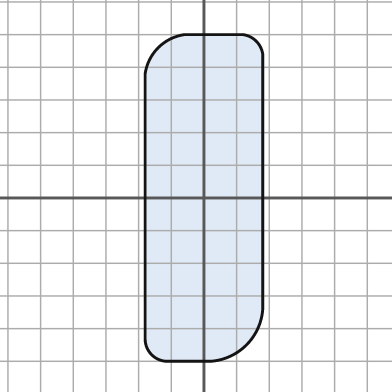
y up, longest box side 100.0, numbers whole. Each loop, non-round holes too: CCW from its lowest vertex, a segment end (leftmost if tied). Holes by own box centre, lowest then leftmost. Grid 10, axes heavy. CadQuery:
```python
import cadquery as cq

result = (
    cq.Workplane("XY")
    .moveTo(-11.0, -50.0)
    .lineTo(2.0, -50.0)
    .threePointArc((13.0, -45.0), (18.0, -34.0))
    .lineTo(18.0, 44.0)
    .threePointArc((16.0, 48.0), (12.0, 50.0))
    .lineTo(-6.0, 50.0)
    .threePointArc((-14.0, 46.0), (-18.0, 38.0))
    .lineTo(-18.0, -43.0)
    .threePointArc((-16.0, -48.0), (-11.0, -50.0))
    .close()
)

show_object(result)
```